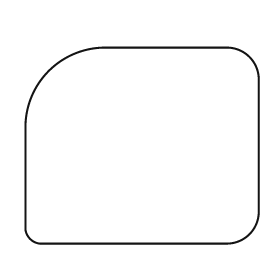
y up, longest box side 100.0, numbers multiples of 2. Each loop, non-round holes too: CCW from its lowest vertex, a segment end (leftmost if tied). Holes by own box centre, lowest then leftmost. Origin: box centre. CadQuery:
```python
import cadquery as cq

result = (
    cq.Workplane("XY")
    .moveTo(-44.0, -42.0)
    .lineTo(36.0, -42.0)
    .threePointArc((46.0, -38.0), (50.0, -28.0))
    .lineTo(50.0, 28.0)
    .threePointArc((46.0, 38.0), (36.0, 42.0))
    .lineTo(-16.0, 42.0)
    .threePointArc((-40.0, 32.0), (-50.0, 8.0))
    .lineTo(-50.0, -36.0)
    .threePointArc((-48.0, -40.0), (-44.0, -42.0))
    .close()
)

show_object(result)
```